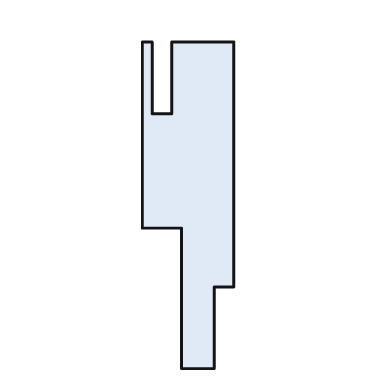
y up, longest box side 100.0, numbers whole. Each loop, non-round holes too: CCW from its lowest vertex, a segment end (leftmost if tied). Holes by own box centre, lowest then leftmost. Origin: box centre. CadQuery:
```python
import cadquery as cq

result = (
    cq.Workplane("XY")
    .moveTo(-2.0, -50.0)
    .lineTo(8.0, -50.0)
    .lineTo(8.0, -25.0)
    .lineTo(14.0, -25.0)
    .lineTo(14.0, 50.0)
    .lineTo(-5.0, 50.0)
    .lineTo(-5.0, 28.0)
    .lineTo(-11.0, 28.0)
    .lineTo(-11.0, 50.0)
    .lineTo(-14.0, 50.0)
    .lineTo(-14.0, -7.0)
    .lineTo(-2.0, -7.0)
    .close()
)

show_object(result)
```